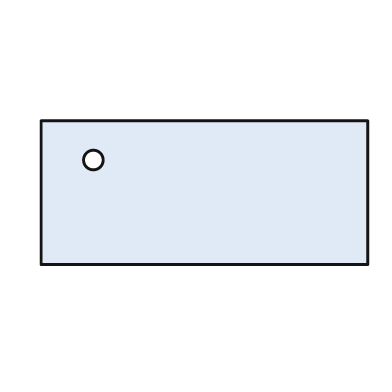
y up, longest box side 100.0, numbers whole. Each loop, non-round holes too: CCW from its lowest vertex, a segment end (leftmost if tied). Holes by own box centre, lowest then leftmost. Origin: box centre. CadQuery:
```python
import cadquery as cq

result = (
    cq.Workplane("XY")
    .moveTo(-50.0, -22.0)
    .lineTo(50.0, -22.0)
    .lineTo(50.0, 22.0)
    .lineTo(-50.0, 22.0)
    .close()
    .moveTo(-34.0, 10.0)
    .circle(3.0)
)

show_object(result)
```